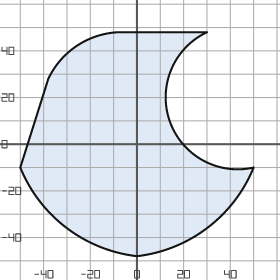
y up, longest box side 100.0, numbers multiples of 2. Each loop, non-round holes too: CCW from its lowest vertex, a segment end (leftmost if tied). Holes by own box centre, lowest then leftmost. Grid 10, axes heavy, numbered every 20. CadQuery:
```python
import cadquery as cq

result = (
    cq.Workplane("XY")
    .moveTo(0.0, -48.0)
    .threePointArc((30.0, -36.0), (50.0, -10.0))
    .threePointArc((14.0, 10.0), (30.0, 48.0))
    .lineTo(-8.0, 48.0)
    .threePointArc((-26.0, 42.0), (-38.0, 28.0))
    .lineTo(-50.0, -10.0)
    .threePointArc((-30.0, -36.0), (0.0, -48.0))
    .close()
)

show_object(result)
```